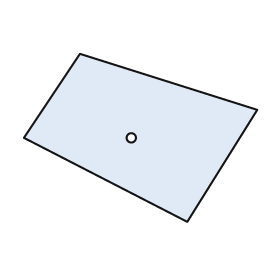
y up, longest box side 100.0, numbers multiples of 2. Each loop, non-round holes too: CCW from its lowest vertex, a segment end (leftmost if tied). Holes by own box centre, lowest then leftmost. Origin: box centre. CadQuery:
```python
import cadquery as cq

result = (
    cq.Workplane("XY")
    .moveTo(20.0, -36.0)
    .lineTo(50.0, 12.0)
    .lineTo(-26.0, 36.0)
    .lineTo(-50.0, 0.0)
    .close()
    .moveTo(-4.0, 0.0)
    .circle(2.0)
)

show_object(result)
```